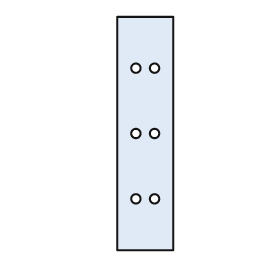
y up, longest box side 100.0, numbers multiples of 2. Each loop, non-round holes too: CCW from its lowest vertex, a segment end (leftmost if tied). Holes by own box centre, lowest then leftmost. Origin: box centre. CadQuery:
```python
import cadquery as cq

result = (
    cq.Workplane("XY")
    .moveTo(-12.0, -50.0)
    .lineTo(12.0, -50.0)
    .lineTo(12.0, 50.0)
    .lineTo(-12.0, 50.0)
    .close()
    .moveTo(-4.0, -28.0)
    .circle(2.0)
    .moveTo(4.0, -28.0)
    .circle(2.0)
    .moveTo(-4.0, 0.0)
    .circle(2.0)
    .moveTo(4.0, 0.0)
    .circle(2.0)
    .moveTo(-4.0, 28.0)
    .circle(2.0)
    .moveTo(4.0, 28.0)
    .circle(2.0)
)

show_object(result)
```